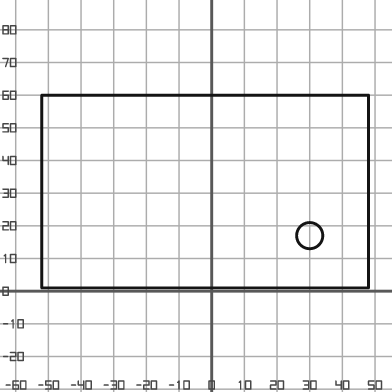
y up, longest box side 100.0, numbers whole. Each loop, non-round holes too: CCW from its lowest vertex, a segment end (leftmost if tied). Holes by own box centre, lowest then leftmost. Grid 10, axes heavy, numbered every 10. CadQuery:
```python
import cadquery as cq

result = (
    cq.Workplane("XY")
    .moveTo(-52.0, 1.0)
    .lineTo(48.0, 1.0)
    .lineTo(48.0, 60.0)
    .lineTo(-52.0, 60.0)
    .close()
    .moveTo(30.0, 17.0)
    .circle(4.0)
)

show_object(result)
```